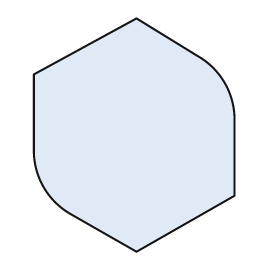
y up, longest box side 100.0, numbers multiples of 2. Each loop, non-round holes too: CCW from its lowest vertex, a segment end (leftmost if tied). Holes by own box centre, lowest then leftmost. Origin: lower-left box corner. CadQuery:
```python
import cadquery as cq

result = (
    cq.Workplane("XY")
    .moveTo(44.0, 0.0)
    .lineTo(86.0, 24.0)
    .lineTo(86.0, 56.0)
    .threePointArc((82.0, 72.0), (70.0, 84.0))
    .lineTo(44.0, 100.0)
    .lineTo(0.0, 76.0)
    .lineTo(0.0, 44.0)
    .threePointArc((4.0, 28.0), (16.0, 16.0))
    .close()
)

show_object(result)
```